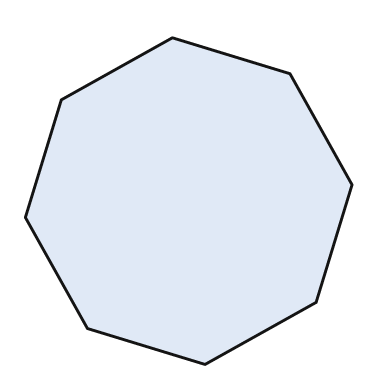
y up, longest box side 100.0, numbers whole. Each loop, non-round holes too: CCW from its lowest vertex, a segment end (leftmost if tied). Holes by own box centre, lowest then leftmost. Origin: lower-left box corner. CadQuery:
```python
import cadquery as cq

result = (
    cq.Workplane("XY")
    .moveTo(55.0, 0.0)
    .lineTo(89.0, 19.0)
    .lineTo(100.0, 55.0)
    .lineTo(81.0, 89.0)
    .lineTo(45.0, 100.0)
    .lineTo(11.0, 81.0)
    .lineTo(0.0, 45.0)
    .lineTo(19.0, 11.0)
    .close()
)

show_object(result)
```